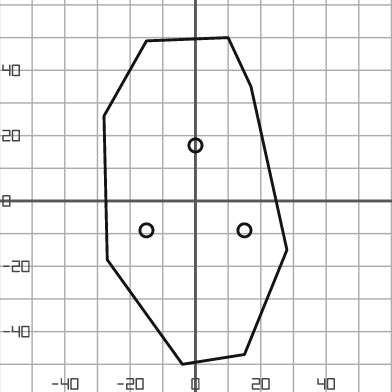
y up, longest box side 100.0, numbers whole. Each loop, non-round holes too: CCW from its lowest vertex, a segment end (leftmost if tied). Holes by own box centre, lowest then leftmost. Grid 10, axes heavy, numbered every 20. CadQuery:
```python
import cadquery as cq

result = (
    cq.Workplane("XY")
    .moveTo(-4.0, -50.0)
    .lineTo(15.0, -47.0)
    .lineTo(28.0, -15.0)
    .lineTo(17.0, 35.0)
    .lineTo(10.0, 50.0)
    .lineTo(-15.0, 49.0)
    .lineTo(-28.0, 26.0)
    .lineTo(-27.0, -18.0)
    .close()
    .moveTo(-15.0, -9.0)
    .circle(2.0)
    .moveTo(15.0, -9.0)
    .circle(2.0)
    .moveTo(0.0, 17.0)
    .circle(2.0)
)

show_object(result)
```